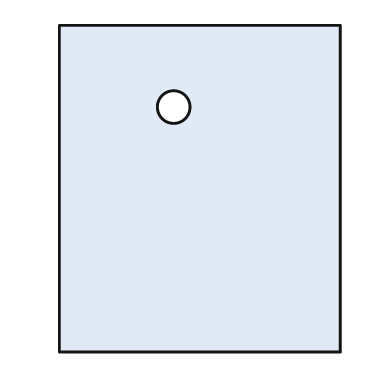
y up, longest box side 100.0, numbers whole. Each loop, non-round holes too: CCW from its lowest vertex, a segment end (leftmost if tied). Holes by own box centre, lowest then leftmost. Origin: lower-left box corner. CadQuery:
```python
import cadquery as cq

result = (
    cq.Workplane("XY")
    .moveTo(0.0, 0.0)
    .lineTo(86.0, 0.0)
    .lineTo(86.0, 100.0)
    .lineTo(0.0, 100.0)
    .close()
    .moveTo(35.0, 75.0)
    .circle(5.0)
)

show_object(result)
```